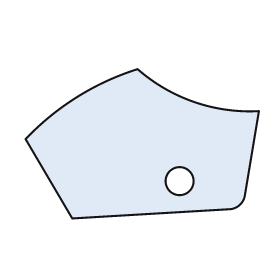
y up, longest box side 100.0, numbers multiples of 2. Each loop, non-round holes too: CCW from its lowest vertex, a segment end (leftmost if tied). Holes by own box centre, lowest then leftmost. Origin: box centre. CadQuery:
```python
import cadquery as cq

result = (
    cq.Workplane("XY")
    .moveTo(-30.0, -32.0)
    .lineTo(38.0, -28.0)
    .threePointArc((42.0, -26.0), (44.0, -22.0))
    .lineTo(50.0, 14.0)
    .threePointArc((22.0, 18.0), (-2.0, 32.0))
    .threePointArc((-28.0, 20.0), (-50.0, 2.0))
    .close()
    .moveTo(16.0, -16.0)
    .circle(6.0)
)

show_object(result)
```